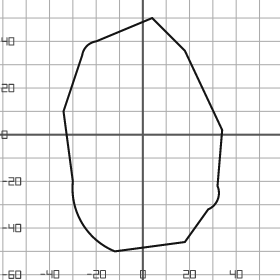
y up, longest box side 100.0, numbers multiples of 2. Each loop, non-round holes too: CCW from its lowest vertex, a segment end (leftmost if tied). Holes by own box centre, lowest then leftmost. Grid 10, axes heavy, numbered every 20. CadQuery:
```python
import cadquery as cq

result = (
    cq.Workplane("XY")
    .moveTo(-12.0, -50.0)
    .lineTo(18.0, -46.0)
    .lineTo(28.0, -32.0)
    .threePointArc((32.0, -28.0), (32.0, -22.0))
    .lineTo(34.0, 2.0)
    .lineTo(18.0, 36.0)
    .lineTo(4.0, 50.0)
    .lineTo(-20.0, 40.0)
    .threePointArc((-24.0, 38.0), (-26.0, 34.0))
    .lineTo(-34.0, 10.0)
    .lineTo(-30.0, -20.0)
    .threePointArc((-26.0, -38.0), (-12.0, -50.0))
    .close()
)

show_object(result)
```